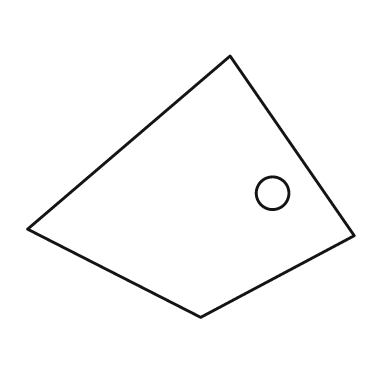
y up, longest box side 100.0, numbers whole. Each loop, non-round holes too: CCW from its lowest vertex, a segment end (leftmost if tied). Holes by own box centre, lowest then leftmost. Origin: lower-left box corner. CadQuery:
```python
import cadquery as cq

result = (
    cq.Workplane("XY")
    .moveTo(53.0, 0.0)
    .lineTo(100.0, 25.0)
    .lineTo(62.0, 80.0)
    .lineTo(0.0, 27.0)
    .close()
    .moveTo(75.0, 38.0)
    .circle(5.0)
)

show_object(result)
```